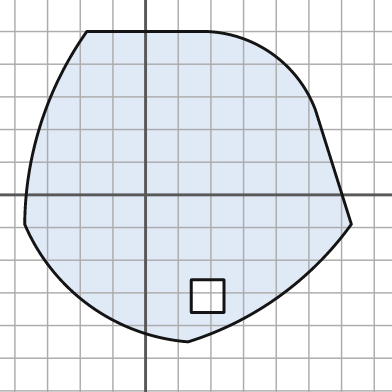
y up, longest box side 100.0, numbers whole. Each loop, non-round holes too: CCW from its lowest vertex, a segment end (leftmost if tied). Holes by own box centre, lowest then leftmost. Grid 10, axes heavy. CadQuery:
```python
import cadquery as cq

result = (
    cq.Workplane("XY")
    .moveTo(13.0, -45.0)
    .threePointArc((41.0, -31.0), (63.0, -9.0))
    .lineTo(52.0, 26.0)
    .threePointArc((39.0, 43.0), (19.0, 50.0))
    .lineTo(-18.0, 50.0)
    .threePointArc((-32.0, 22.0), (-37.0, -9.0))
    .threePointArc((-17.0, -34.0), (13.0, -45.0))
    .close()
    .moveTo(14.0, -36.0)
    .lineTo(24.0, -36.0)
    .lineTo(24.0, -26.0)
    .lineTo(14.0, -26.0)
    .close()
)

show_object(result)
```